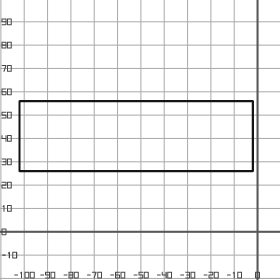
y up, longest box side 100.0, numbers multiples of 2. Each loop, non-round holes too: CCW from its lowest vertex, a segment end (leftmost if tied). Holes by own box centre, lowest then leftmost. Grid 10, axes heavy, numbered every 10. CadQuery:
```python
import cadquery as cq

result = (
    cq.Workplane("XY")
    .moveTo(-102.0, 26.0)
    .lineTo(-2.0, 26.0)
    .lineTo(-2.0, 56.0)
    .lineTo(-102.0, 56.0)
    .close()
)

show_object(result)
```